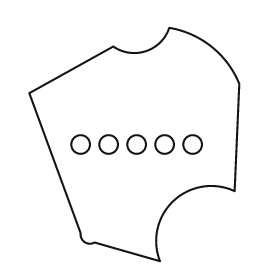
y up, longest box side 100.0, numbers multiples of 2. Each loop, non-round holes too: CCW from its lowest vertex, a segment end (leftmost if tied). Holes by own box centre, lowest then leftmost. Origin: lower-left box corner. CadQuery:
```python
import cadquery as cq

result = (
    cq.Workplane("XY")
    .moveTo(56.0, 0.0)
    .threePointArc((62.0, 26.0), (88.0, 30.0))
    .lineTo(90.0, 76.0)
    .threePointArc((78.0, 92.0), (60.0, 100.0))
    .threePointArc((50.0, 90.0), (36.0, 92.0))
    .lineTo(0.0, 72.0)
    .lineTo(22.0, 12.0)
    .threePointArc((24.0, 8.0), (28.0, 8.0))
    .close()
    .moveTo(22.0, 50.0)
    .circle(4.0)
    .moveTo(34.0, 50.0)
    .circle(4.0)
    .moveTo(46.0, 50.0)
    .circle(4.0)
    .moveTo(58.0, 50.0)
    .circle(4.0)
    .moveTo(70.0, 50.0)
    .circle(4.0)
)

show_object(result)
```